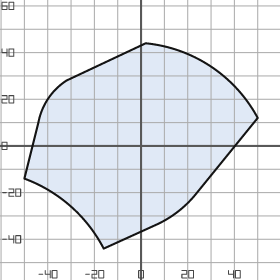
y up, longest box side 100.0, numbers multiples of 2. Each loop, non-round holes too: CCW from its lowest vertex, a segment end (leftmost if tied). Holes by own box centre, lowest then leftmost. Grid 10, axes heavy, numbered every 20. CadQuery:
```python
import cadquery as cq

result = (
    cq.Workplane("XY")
    .moveTo(-16.0, -44.0)
    .lineTo(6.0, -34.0)
    .threePointArc((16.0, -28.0), (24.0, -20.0))
    .lineTo(50.0, 12.0)
    .threePointArc((30.0, 34.0), (2.0, 44.0))
    .lineTo(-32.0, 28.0)
    .threePointArc((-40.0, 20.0), (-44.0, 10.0))
    .lineTo(-50.0, -14.0)
    .threePointArc((-30.0, -26.0), (-16.0, -44.0))
    .close()
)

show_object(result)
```